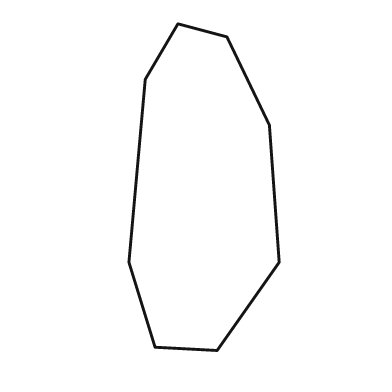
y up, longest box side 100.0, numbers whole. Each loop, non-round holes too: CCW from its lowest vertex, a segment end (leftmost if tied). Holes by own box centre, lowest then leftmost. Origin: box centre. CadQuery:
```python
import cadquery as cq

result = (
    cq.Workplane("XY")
    .moveTo(4.0, -50.0)
    .lineTo(23.0, -23.0)
    .lineTo(20.0, 19.0)
    .lineTo(7.0, 46.0)
    .lineTo(-8.0, 50.0)
    .lineTo(-18.0, 33.0)
    .lineTo(-23.0, -23.0)
    .lineTo(-15.0, -49.0)
    .close()
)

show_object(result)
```